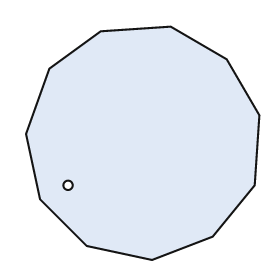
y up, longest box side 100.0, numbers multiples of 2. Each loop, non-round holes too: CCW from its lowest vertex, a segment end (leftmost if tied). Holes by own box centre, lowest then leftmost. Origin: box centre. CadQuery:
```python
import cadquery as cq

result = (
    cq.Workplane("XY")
    .moveTo(4.0, -50.0)
    .lineTo(30.0, -40.0)
    .lineTo(48.0, -18.0)
    .lineTo(50.0, 12.0)
    .lineTo(36.0, 36.0)
    .lineTo(12.0, 50.0)
    .lineTo(-18.0, 48.0)
    .lineTo(-40.0, 32.0)
    .lineTo(-50.0, 4.0)
    .lineTo(-44.0, -24.0)
    .lineTo(-24.0, -44.0)
    .close()
    .moveTo(-32.0, -18.0)
    .circle(2.0)
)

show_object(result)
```